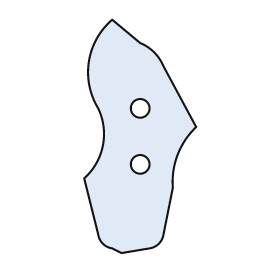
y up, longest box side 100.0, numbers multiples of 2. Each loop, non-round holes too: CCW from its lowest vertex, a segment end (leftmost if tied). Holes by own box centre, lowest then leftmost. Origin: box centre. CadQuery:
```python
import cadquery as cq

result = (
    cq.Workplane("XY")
    .moveTo(-8.0, -50.0)
    .lineTo(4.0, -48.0)
    .threePointArc((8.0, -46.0), (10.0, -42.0))
    .lineTo(14.0, -22.0)
    .threePointArc((16.0, -8.0), (24.0, 4.0))
    .lineTo(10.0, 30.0)
    .threePointArc((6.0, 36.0), (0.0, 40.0))
    .lineTo(-12.0, 50.0)
    .threePointArc((-22.0, 32.0), (-18.0, 12.0))
    .threePointArc((-16.0, -4.0), (-24.0, -18.0))
    .lineTo(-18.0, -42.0)
    .threePointArc((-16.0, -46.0), (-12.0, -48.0))
    .close()
    .moveTo(0.0, -12.0)
    .circle(4.0)
    .moveTo(0.0, 12.0)
    .circle(4.0)
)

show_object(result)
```